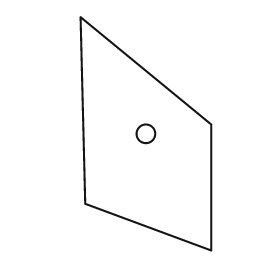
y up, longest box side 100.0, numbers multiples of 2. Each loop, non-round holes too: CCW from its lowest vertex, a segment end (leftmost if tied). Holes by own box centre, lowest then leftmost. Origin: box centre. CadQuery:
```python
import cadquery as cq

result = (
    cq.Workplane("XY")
    .moveTo(28.0, -50.0)
    .lineTo(28.0, 4.0)
    .lineTo(-28.0, 50.0)
    .lineTo(-26.0, -30.0)
    .close()
    .moveTo(0.0, 0.0)
    .circle(4.0)
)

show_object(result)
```